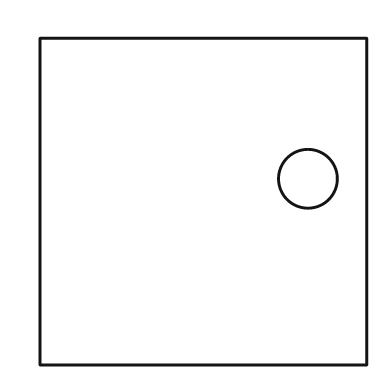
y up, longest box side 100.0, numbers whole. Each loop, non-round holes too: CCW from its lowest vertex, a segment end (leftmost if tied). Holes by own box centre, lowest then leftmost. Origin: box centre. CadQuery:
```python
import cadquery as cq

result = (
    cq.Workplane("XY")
    .moveTo(-50.0, -50.0)
    .lineTo(50.0, -50.0)
    .lineTo(50.0, 50.0)
    .lineTo(-50.0, 50.0)
    .close()
    .moveTo(32.0, 7.0)
    .circle(9.0)
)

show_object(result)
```